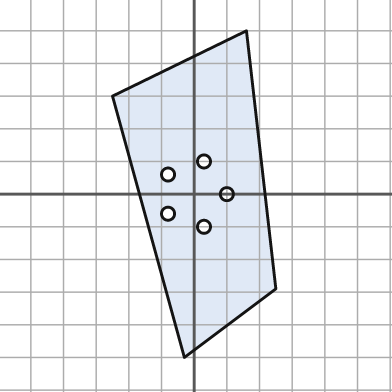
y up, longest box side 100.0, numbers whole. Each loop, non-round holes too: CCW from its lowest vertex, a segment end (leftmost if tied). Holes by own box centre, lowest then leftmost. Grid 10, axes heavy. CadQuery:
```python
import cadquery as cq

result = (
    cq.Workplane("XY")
    .moveTo(-3.0, -50.0)
    .lineTo(25.0, -29.0)
    .lineTo(16.0, 50.0)
    .lineTo(-25.0, 30.0)
    .close()
    .moveTo(3.0, -10.0)
    .circle(2.0)
    .moveTo(-8.0, -6.0)
    .circle(2.0)
    .moveTo(10.0, 0.0)
    .circle(2.0)
    .moveTo(-8.0, 6.0)
    .circle(2.0)
    .moveTo(3.0, 10.0)
    .circle(2.0)
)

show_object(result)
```